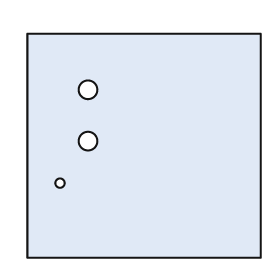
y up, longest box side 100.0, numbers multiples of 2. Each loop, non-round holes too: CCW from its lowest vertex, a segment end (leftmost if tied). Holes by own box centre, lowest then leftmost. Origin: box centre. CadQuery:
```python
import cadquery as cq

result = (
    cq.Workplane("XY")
    .moveTo(-50.0, -48.0)
    .lineTo(50.0, -48.0)
    .lineTo(50.0, 48.0)
    .lineTo(-50.0, 48.0)
    .close()
    .moveTo(-36.0, -16.0)
    .circle(2.0)
    .moveTo(-24.0, 2.0)
    .circle(4.0)
    .moveTo(-24.0, 24.0)
    .circle(4.0)
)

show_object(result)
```